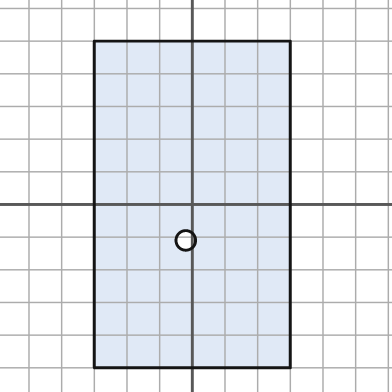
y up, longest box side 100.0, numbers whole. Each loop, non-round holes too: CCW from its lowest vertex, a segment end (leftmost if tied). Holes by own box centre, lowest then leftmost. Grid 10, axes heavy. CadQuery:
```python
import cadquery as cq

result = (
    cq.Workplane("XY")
    .moveTo(-30.0, -50.0)
    .lineTo(30.0, -50.0)
    .lineTo(30.0, 50.0)
    .lineTo(-30.0, 50.0)
    .close()
    .moveTo(-2.0, -11.0)
    .circle(3.0)
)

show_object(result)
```